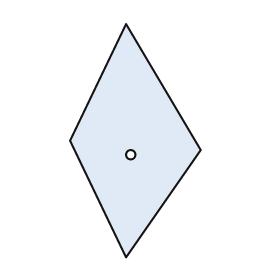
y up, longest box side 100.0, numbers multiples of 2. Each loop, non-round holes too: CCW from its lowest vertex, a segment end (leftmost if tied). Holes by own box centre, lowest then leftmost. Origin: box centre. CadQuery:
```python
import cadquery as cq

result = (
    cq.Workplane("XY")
    .moveTo(-4.0, -50.0)
    .lineTo(28.0, -4.0)
    .lineTo(-4.0, 50.0)
    .lineTo(-28.0, 0.0)
    .close()
    .moveTo(-2.0, -6.0)
    .circle(2.0)
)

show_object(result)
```